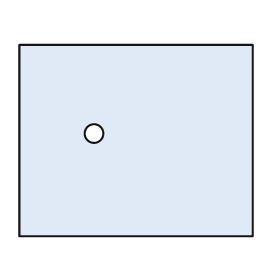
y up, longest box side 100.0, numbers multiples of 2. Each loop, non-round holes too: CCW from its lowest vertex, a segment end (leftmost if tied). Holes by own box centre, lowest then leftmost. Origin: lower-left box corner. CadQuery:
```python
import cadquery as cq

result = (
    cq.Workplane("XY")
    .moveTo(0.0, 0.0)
    .lineTo(100.0, 0.0)
    .lineTo(100.0, 82.0)
    .lineTo(0.0, 82.0)
    .close()
    .moveTo(32.0, 44.0)
    .circle(4.0)
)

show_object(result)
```